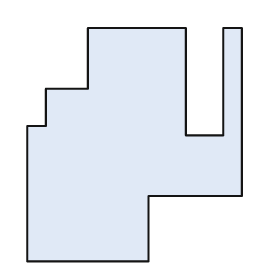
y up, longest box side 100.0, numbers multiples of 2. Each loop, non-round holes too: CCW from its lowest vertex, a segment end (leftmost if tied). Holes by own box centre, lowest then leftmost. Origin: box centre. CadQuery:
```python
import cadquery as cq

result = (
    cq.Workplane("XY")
    .moveTo(-46.0, -50.0)
    .lineTo(6.0, -50.0)
    .lineTo(6.0, -22.0)
    .lineTo(46.0, -22.0)
    .lineTo(46.0, 50.0)
    .lineTo(38.0, 50.0)
    .lineTo(38.0, 4.0)
    .lineTo(22.0, 4.0)
    .lineTo(22.0, 50.0)
    .lineTo(-20.0, 50.0)
    .lineTo(-20.0, 24.0)
    .lineTo(-38.0, 24.0)
    .lineTo(-38.0, 8.0)
    .lineTo(-46.0, 8.0)
    .close()
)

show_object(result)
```